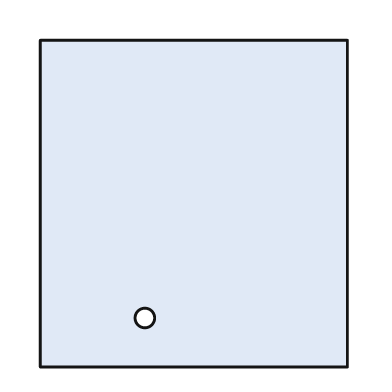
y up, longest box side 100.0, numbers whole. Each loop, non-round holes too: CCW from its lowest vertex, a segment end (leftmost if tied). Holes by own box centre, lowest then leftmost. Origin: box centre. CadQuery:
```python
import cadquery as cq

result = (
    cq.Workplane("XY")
    .moveTo(-47.0, -50.0)
    .lineTo(47.0, -50.0)
    .lineTo(47.0, 50.0)
    .lineTo(-47.0, 50.0)
    .close()
    .moveTo(-15.0, -35.0)
    .circle(3.0)
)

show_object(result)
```